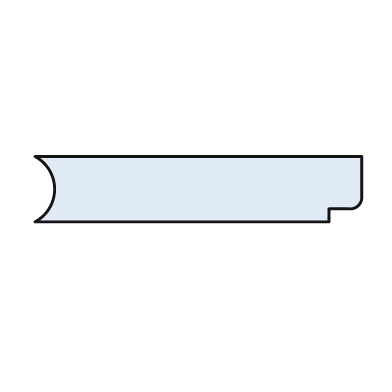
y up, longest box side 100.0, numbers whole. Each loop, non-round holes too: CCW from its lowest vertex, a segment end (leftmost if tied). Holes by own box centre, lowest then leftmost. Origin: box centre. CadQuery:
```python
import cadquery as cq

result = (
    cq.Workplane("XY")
    .moveTo(-50.0, -10.0)
    .lineTo(40.0, -10.0)
    .lineTo(40.0, -6.0)
    .lineTo(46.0, -6.0)
    .threePointArc((49.0, -5.0), (50.0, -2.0))
    .lineTo(50.0, 10.0)
    .lineTo(-50.0, 10.0)
    .threePointArc((-44.0, 0.0), (-50.0, -10.0))
    .close()
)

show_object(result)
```